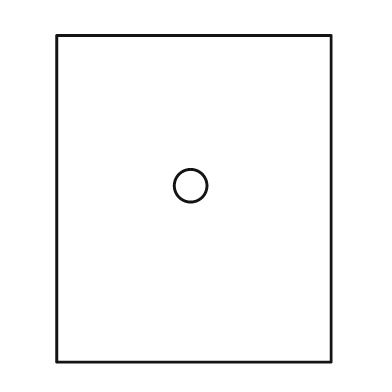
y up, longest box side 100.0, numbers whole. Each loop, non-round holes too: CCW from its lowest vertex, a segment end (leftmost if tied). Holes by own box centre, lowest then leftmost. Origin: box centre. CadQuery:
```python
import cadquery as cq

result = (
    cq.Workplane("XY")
    .moveTo(-42.0, -50.0)
    .lineTo(42.0, -50.0)
    .lineTo(42.0, 50.0)
    .lineTo(-42.0, 50.0)
    .close()
    .moveTo(-1.0, 4.0)
    .circle(5.0)
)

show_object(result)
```